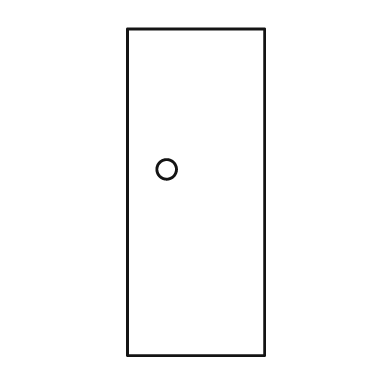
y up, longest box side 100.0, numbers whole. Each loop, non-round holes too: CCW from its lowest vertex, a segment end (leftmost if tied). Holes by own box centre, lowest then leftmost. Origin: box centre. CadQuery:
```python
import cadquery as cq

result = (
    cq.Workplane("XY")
    .moveTo(-21.0, -50.0)
    .lineTo(21.0, -50.0)
    .lineTo(21.0, 50.0)
    .lineTo(-21.0, 50.0)
    .close()
    .moveTo(-9.0, 7.0)
    .circle(3.0)
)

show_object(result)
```